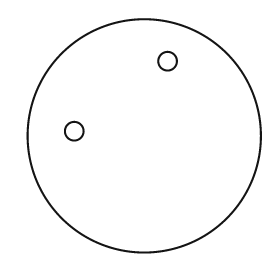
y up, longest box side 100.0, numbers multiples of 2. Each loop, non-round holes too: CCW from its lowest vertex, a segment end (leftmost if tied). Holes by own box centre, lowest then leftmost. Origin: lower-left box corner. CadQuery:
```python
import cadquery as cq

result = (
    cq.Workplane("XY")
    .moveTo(50.0, 50.0)
    .circle(50.0)
    .moveTo(20.0, 52.0)
    .circle(4.0)
    .moveTo(60.0, 82.0)
    .circle(4.0)
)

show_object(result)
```